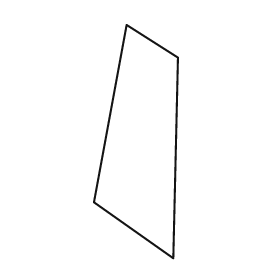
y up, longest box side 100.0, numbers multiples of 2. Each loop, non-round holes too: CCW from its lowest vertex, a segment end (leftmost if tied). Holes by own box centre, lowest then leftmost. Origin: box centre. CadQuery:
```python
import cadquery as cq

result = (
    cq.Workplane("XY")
    .moveTo(16.0, -50.0)
    .lineTo(18.0, 36.0)
    .lineTo(-4.0, 50.0)
    .lineTo(-18.0, -26.0)
    .close()
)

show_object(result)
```